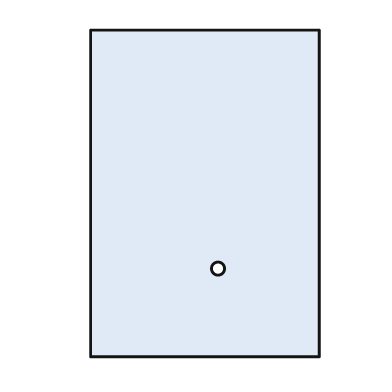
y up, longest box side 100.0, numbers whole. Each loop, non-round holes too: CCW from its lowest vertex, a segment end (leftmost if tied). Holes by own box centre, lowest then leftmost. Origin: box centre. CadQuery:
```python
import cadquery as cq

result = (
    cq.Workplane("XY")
    .moveTo(-35.0, -50.0)
    .lineTo(35.0, -50.0)
    .lineTo(35.0, 50.0)
    .lineTo(-35.0, 50.0)
    .close()
    .moveTo(4.0, -23.0)
    .circle(2.0)
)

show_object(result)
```